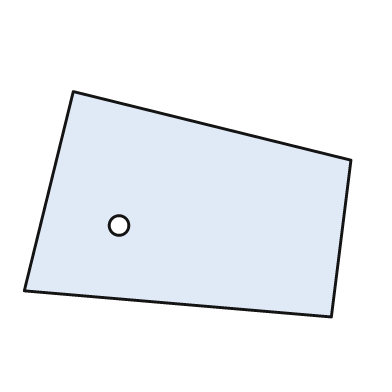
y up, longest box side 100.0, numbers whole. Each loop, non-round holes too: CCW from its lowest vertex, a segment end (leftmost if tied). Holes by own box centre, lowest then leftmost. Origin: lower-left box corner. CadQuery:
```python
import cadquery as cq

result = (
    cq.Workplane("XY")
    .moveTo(94.0, 0.0)
    .lineTo(100.0, 48.0)
    .lineTo(15.0, 69.0)
    .lineTo(0.0, 8.0)
    .close()
    .moveTo(29.0, 28.0)
    .circle(3.0)
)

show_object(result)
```